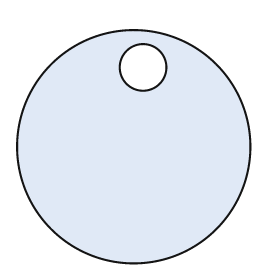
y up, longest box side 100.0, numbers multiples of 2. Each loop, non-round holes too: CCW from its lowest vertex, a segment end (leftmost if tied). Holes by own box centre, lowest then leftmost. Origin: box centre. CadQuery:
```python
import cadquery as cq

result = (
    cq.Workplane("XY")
    .moveTo(0.0, 0.0)
    .circle(50.0)
    .moveTo(4.0, 34.0)
    .circle(10.0)
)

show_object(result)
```